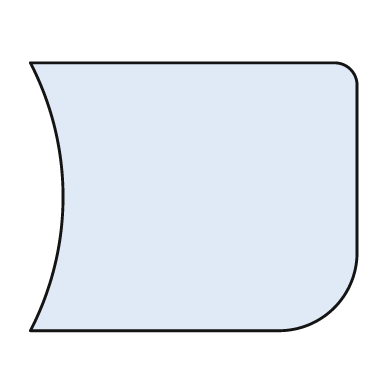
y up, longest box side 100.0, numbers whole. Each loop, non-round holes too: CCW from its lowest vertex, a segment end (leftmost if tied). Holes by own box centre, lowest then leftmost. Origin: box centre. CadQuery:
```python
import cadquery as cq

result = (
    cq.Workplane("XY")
    .moveTo(-50.0, -41.0)
    .lineTo(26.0, -41.0)
    .threePointArc((43.0, -34.0), (50.0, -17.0))
    .lineTo(50.0, 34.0)
    .threePointArc((48.0, 39.0), (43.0, 41.0))
    .lineTo(-50.0, 41.0)
    .threePointArc((-40.0, 0.0), (-50.0, -41.0))
    .close()
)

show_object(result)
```